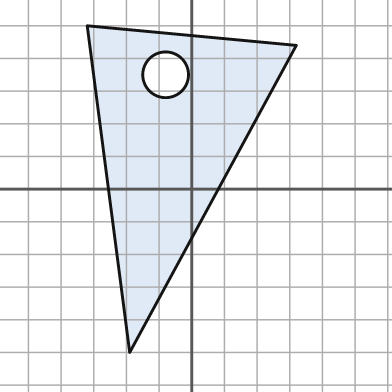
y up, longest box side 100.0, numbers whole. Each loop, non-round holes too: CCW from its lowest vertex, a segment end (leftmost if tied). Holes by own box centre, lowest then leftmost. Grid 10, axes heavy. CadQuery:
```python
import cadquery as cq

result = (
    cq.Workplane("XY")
    .moveTo(-19.0, -50.0)
    .lineTo(32.0, 44.0)
    .lineTo(-32.0, 50.0)
    .close()
    .moveTo(-8.0, 35.0)
    .circle(7.0)
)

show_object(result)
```